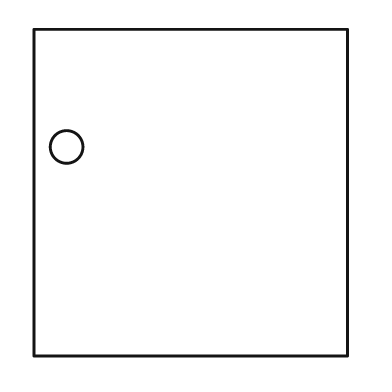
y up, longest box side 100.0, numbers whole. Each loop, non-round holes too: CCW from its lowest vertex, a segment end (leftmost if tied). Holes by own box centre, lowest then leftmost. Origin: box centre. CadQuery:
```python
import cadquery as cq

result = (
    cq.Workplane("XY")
    .moveTo(-48.0, -50.0)
    .lineTo(48.0, -50.0)
    .lineTo(48.0, 50.0)
    .lineTo(-48.0, 50.0)
    .close()
    .moveTo(-38.0, 14.0)
    .circle(5.0)
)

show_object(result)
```